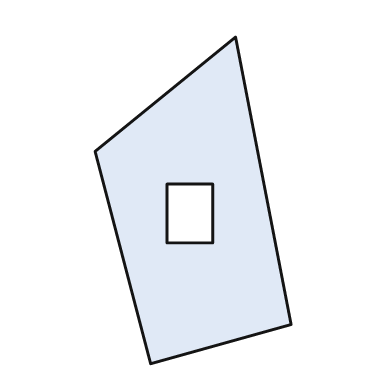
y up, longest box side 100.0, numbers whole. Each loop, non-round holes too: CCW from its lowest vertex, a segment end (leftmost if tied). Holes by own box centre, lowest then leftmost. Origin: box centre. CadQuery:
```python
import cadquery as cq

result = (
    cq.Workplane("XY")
    .moveTo(-13.0, -50.0)
    .lineTo(30.0, -38.0)
    .lineTo(13.0, 50.0)
    .lineTo(-30.0, 15.0)
    .close()
    .moveTo(-8.0, -13.0)
    .lineTo(6.0, -13.0)
    .lineTo(6.0, 5.0)
    .lineTo(-8.0, 5.0)
    .close()
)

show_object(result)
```